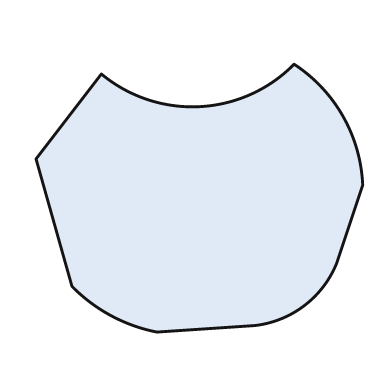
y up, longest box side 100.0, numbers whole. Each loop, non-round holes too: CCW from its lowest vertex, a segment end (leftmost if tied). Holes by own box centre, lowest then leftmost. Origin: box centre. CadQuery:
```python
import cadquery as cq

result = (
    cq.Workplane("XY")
    .moveTo(-13.0, -41.0)
    .lineTo(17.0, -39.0)
    .threePointArc((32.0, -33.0), (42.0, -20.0))
    .lineTo(50.0, 4.0)
    .threePointArc((44.0, 25.0), (29.0, 41.0))
    .threePointArc((0.0, 28.0), (-30.0, 38.0))
    .lineTo(-50.0, 12.0)
    .lineTo(-39.0, -27.0)
    .threePointArc((-27.0, -36.0), (-13.0, -41.0))
    .close()
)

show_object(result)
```